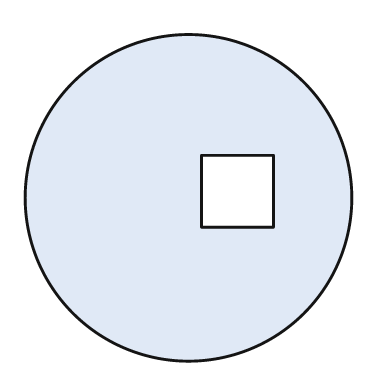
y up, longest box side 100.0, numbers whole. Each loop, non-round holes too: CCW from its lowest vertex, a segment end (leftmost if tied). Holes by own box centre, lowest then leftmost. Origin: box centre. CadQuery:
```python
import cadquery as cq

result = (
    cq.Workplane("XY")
    .moveTo(0.0, 0.0)
    .circle(50.0)
    .moveTo(4.0, -9.0)
    .lineTo(26.0, -9.0)
    .lineTo(26.0, 13.0)
    .lineTo(4.0, 13.0)
    .close()
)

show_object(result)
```